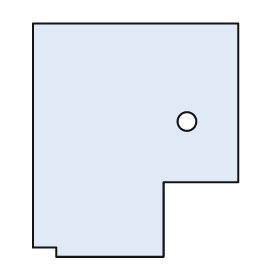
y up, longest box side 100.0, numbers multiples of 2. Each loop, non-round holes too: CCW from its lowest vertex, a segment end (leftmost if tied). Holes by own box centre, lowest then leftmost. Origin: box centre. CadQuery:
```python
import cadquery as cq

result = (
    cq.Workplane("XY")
    .moveTo(-34.0, -50.0)
    .lineTo(12.0, -50.0)
    .lineTo(12.0, -18.0)
    .lineTo(44.0, -18.0)
    .lineTo(44.0, 50.0)
    .lineTo(-44.0, 50.0)
    .lineTo(-44.0, -46.0)
    .lineTo(-34.0, -46.0)
    .close()
    .moveTo(22.0, 8.0)
    .circle(4.0)
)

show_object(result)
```